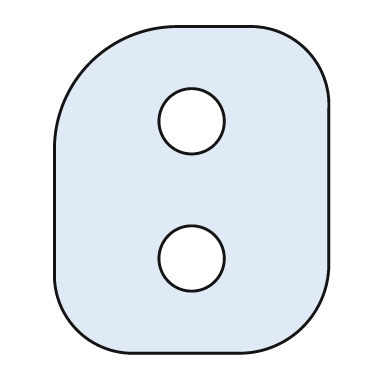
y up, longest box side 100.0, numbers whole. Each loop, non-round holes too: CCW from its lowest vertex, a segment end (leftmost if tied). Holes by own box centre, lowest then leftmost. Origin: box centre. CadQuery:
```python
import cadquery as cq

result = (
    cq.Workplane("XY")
    .moveTo(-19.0, -50.0)
    .lineTo(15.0, -50.0)
    .threePointArc((34.0, -42.0), (42.0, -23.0))
    .lineTo(42.0, 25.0)
    .threePointArc((35.0, 43.0), (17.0, 50.0))
    .lineTo(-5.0, 50.0)
    .threePointArc((-31.0, 39.0), (-42.0, 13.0))
    .lineTo(-42.0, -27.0)
    .threePointArc((-35.0, -43.0), (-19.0, -50.0))
    .close()
    .moveTo(0.0, -21.0)
    .circle(10.0)
    .moveTo(0.0, 21.0)
    .circle(10.0)
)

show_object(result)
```